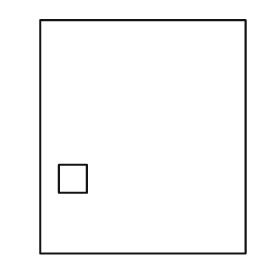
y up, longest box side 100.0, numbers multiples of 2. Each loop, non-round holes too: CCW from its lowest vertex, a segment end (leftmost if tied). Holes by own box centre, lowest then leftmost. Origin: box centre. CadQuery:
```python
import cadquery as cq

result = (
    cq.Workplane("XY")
    .moveTo(-44.0, -50.0)
    .lineTo(44.0, -50.0)
    .lineTo(44.0, 50.0)
    .lineTo(-44.0, 50.0)
    .close()
    .moveTo(-36.0, -24.0)
    .lineTo(-24.0, -24.0)
    .lineTo(-24.0, -12.0)
    .lineTo(-36.0, -12.0)
    .close()
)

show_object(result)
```